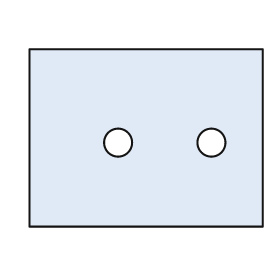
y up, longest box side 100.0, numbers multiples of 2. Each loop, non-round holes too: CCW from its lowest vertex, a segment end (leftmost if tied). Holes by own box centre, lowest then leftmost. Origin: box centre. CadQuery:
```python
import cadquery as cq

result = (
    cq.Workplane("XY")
    .moveTo(-50.0, -38.0)
    .lineTo(50.0, -38.0)
    .lineTo(50.0, 38.0)
    .lineTo(-50.0, 38.0)
    .close()
    .moveTo(-12.0, -2.0)
    .circle(6.0)
    .moveTo(28.0, -2.0)
    .circle(6.0)
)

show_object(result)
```